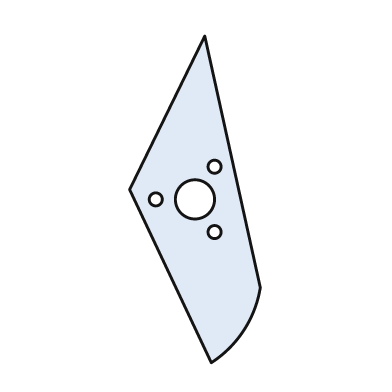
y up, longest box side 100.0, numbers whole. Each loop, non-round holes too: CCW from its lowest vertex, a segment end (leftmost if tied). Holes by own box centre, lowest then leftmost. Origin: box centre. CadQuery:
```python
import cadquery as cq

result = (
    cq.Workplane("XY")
    .moveTo(5.0, -50.0)
    .threePointArc((15.0, -40.0), (20.0, -27.0))
    .lineTo(3.0, 50.0)
    .lineTo(-20.0, 3.0)
    .close()
    .moveTo(6.0, -10.0)
    .circle(2.0)
    .moveTo(-12.0, 0.0)
    .circle(2.0)
    .moveTo(0.0, 0.0)
    .circle(6.0)
    .moveTo(6.0, 10.0)
    .circle(2.0)
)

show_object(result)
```